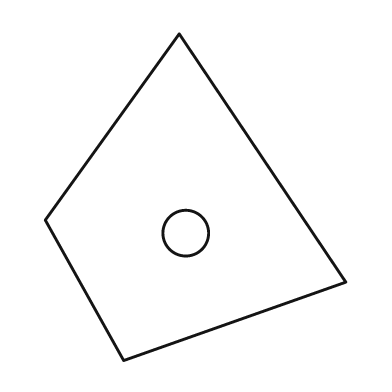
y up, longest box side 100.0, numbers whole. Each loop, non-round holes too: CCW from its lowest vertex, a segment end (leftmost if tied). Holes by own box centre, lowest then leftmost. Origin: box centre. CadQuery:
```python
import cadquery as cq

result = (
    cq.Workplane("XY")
    .moveTo(-22.0, -50.0)
    .lineTo(46.0, -26.0)
    .lineTo(-5.0, 50.0)
    .lineTo(-46.0, -7.0)
    .close()
    .moveTo(-3.0, -11.0)
    .circle(7.0)
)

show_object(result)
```